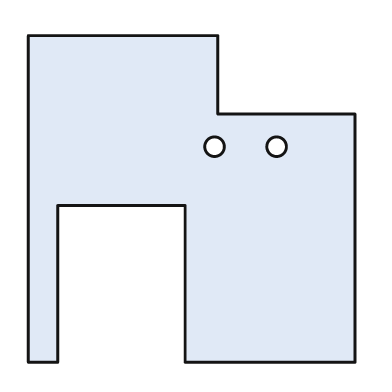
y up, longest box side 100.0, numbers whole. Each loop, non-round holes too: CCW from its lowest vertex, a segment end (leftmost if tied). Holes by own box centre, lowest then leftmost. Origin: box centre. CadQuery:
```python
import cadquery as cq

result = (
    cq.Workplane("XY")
    .moveTo(-50.0, -50.0)
    .lineTo(-41.0, -50.0)
    .lineTo(-41.0, -2.0)
    .lineTo(-2.0, -2.0)
    .lineTo(-2.0, -50.0)
    .lineTo(50.0, -50.0)
    .lineTo(50.0, 26.0)
    .lineTo(8.0, 26.0)
    .lineTo(8.0, 50.0)
    .lineTo(-50.0, 50.0)
    .close()
    .moveTo(7.0, 16.0)
    .circle(3.0)
    .moveTo(26.0, 16.0)
    .circle(3.0)
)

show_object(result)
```